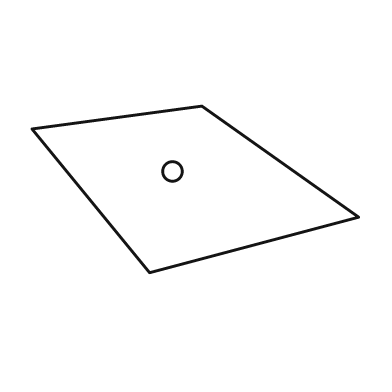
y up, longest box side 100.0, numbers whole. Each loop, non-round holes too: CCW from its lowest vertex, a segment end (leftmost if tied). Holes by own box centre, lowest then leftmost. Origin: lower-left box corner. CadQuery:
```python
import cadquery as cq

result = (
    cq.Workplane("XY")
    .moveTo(36.0, 0.0)
    .lineTo(100.0, 17.0)
    .lineTo(52.0, 51.0)
    .lineTo(0.0, 44.0)
    .close()
    .moveTo(43.0, 31.0)
    .circle(3.0)
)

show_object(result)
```